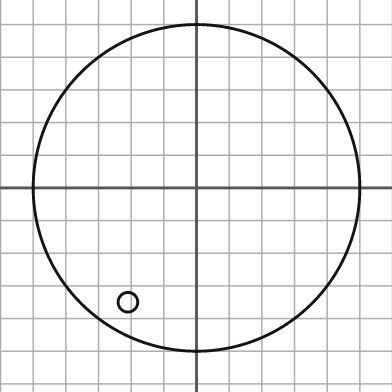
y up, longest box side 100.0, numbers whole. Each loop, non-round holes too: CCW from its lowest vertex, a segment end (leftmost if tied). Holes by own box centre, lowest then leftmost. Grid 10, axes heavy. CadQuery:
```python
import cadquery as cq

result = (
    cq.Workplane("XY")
    .moveTo(0.0, 0.0)
    .circle(50.0)
    .moveTo(-21.0, -35.0)
    .circle(3.0)
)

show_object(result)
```